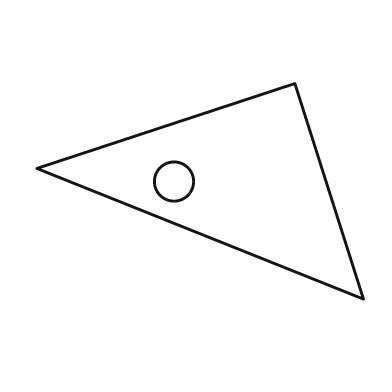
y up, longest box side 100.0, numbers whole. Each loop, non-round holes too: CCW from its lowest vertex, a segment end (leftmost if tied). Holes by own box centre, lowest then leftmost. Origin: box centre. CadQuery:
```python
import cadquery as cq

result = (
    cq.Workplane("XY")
    .moveTo(50.0, -33.0)
    .lineTo(29.0, 33.0)
    .lineTo(-50.0, 7.0)
    .close()
    .moveTo(-8.0, 3.0)
    .circle(6.0)
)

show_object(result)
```